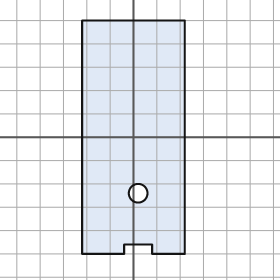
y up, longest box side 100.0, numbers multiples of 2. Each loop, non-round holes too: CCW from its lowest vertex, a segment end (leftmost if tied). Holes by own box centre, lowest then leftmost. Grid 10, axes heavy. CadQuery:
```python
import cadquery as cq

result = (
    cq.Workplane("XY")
    .moveTo(-22.0, -50.0)
    .lineTo(-4.0, -50.0)
    .lineTo(-4.0, -46.0)
    .lineTo(8.0, -46.0)
    .lineTo(8.0, -50.0)
    .lineTo(22.0, -50.0)
    .lineTo(22.0, 50.0)
    .lineTo(-22.0, 50.0)
    .close()
    .moveTo(2.0, -24.0)
    .circle(4.0)
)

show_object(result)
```